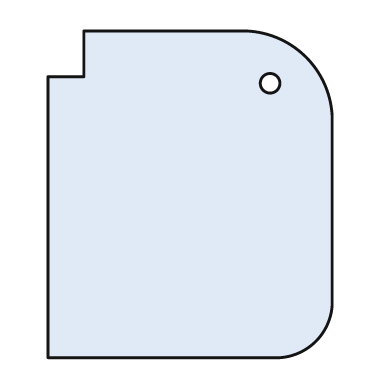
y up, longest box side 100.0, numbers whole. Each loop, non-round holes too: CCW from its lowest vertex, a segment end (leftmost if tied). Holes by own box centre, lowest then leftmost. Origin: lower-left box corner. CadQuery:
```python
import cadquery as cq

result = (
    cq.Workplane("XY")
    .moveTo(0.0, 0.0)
    .lineTo(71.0, 0.0)
    .threePointArc((82.0, 5.0), (87.0, 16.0))
    .lineTo(87.0, 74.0)
    .threePointArc((79.0, 92.0), (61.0, 100.0))
    .lineTo(11.0, 100.0)
    .lineTo(11.0, 86.0)
    .lineTo(0.0, 86.0)
    .close()
    .moveTo(68.0, 84.0)
    .circle(3.0)
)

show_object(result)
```